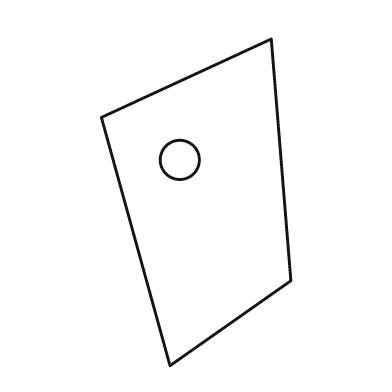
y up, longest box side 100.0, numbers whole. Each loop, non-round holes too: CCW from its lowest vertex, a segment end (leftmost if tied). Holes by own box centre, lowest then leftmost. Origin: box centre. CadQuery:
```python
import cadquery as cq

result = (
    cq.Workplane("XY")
    .moveTo(-8.0, -50.0)
    .lineTo(29.0, -24.0)
    .lineTo(23.0, 50.0)
    .lineTo(-29.0, 26.0)
    .close()
    .moveTo(-5.0, 13.0)
    .circle(6.0)
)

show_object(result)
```